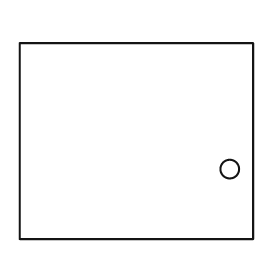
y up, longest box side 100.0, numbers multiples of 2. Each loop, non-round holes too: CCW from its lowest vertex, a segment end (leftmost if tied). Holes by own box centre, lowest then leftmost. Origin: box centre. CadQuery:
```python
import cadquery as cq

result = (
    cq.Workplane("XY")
    .moveTo(-50.0, -42.0)
    .lineTo(50.0, -42.0)
    .lineTo(50.0, 42.0)
    .lineTo(-50.0, 42.0)
    .close()
    .moveTo(40.0, -12.0)
    .circle(4.0)
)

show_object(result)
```